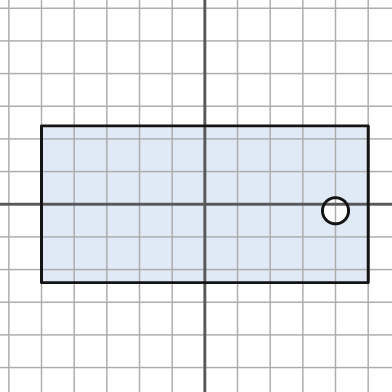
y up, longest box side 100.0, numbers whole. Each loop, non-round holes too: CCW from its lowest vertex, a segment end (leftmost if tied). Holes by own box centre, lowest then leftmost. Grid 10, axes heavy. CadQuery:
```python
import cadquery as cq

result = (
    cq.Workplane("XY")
    .moveTo(-50.0, -24.0)
    .lineTo(50.0, -24.0)
    .lineTo(50.0, 24.0)
    .lineTo(-50.0, 24.0)
    .close()
    .moveTo(40.0, -2.0)
    .circle(4.0)
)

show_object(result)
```